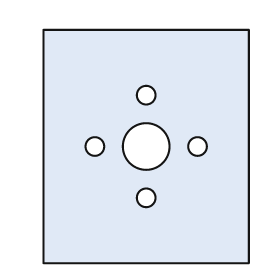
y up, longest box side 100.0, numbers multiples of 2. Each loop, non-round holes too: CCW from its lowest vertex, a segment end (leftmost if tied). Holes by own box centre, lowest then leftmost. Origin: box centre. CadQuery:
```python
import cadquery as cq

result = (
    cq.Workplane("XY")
    .moveTo(-44.0, -50.0)
    .lineTo(44.0, -50.0)
    .lineTo(44.0, 50.0)
    .lineTo(-44.0, 50.0)
    .close()
    .moveTo(0.0, -22.0)
    .circle(4.0)
    .moveTo(-22.0, 0.0)
    .circle(4.0)
    .moveTo(0.0, 0.0)
    .circle(10.0)
    .moveTo(22.0, 0.0)
    .circle(4.0)
    .moveTo(0.0, 22.0)
    .circle(4.0)
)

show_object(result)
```